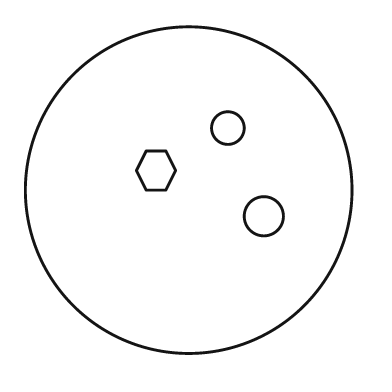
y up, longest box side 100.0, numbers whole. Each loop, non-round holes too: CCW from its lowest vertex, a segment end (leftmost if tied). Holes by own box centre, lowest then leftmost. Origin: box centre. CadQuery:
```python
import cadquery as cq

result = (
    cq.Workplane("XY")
    .moveTo(0.0, 0.0)
    .circle(50.0)
    .moveTo(23.0, -8.0)
    .circle(6.0)
    .moveTo(-13.0, 0.0)
    .lineTo(-7.0, 0.0)
    .lineTo(-4.0, 6.0)
    .lineTo(-7.0, 12.0)
    .lineTo(-13.0, 12.0)
    .lineTo(-16.0, 6.0)
    .close()
    .moveTo(12.0, 19.0)
    .circle(5.0)
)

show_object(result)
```